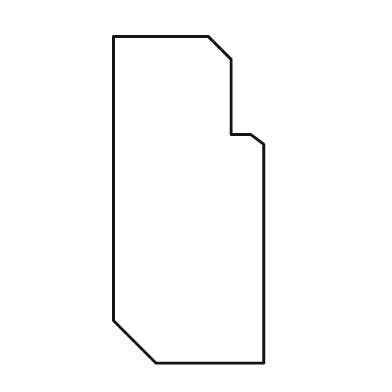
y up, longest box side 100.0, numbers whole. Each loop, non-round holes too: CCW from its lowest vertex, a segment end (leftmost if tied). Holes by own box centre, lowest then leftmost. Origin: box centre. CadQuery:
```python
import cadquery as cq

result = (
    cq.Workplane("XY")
    .moveTo(-10.0, -50.0)
    .lineTo(23.0, -50.0)
    .lineTo(23.0, 17.0)
    .lineTo(19.0, 20.0)
    .lineTo(13.0, 20.0)
    .lineTo(13.0, 43.0)
    .lineTo(6.0, 50.0)
    .lineTo(-23.0, 50.0)
    .lineTo(-23.0, -37.0)
    .close()
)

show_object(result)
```